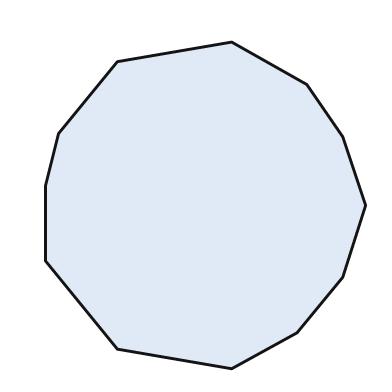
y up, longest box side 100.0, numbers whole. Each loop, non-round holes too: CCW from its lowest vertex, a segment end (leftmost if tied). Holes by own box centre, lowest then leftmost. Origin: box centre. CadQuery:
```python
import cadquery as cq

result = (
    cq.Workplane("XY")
    .moveTo(8.0, -50.0)
    .lineTo(28.0, -39.0)
    .lineTo(42.0, -22.0)
    .lineTo(49.0, 0.0)
    .lineTo(42.0, 21.0)
    .lineTo(31.0, 37.0)
    .lineTo(8.0, 50.0)
    .lineTo(-27.0, 44.0)
    .lineTo(-45.0, 22.0)
    .lineTo(-49.0, 6.0)
    .lineTo(-49.0, -17.0)
    .lineTo(-27.0, -44.0)
    .close()
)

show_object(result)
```